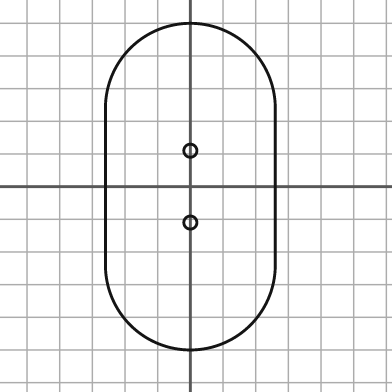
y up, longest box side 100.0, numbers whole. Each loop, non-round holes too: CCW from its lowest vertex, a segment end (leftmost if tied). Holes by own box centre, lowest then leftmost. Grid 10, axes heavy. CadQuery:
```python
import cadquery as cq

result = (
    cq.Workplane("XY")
    .moveTo(-26.0, -24.0)
    .threePointArc((0.0, -50.0), (26.0, -24.0))
    .lineTo(26.0, 24.0)
    .threePointArc((0.0, 50.0), (-26.0, 24.0))
    .close()
    .moveTo(0.0, -11.0)
    .circle(2.0)
    .moveTo(0.0, 11.0)
    .circle(2.0)
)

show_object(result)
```